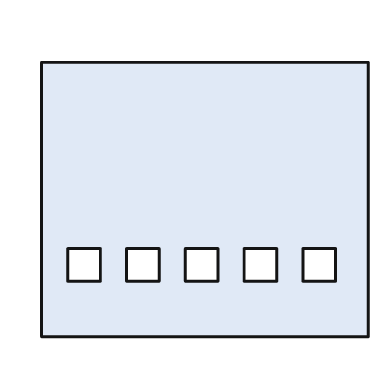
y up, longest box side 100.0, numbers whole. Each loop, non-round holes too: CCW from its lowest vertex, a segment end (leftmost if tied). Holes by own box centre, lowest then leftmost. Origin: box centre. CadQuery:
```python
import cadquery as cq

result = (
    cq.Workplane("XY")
    .moveTo(-50.0, -42.0)
    .lineTo(50.0, -42.0)
    .lineTo(50.0, 42.0)
    .lineTo(-50.0, 42.0)
    .close()
    .moveTo(-42.0, -25.0)
    .lineTo(-32.0, -25.0)
    .lineTo(-32.0, -15.0)
    .lineTo(-42.0, -15.0)
    .close()
    .moveTo(-24.0, -25.0)
    .lineTo(-14.0, -25.0)
    .lineTo(-14.0, -15.0)
    .lineTo(-24.0, -15.0)
    .close()
    .moveTo(-6.0, -25.0)
    .lineTo(4.0, -25.0)
    .lineTo(4.0, -15.0)
    .lineTo(-6.0, -15.0)
    .close()
    .moveTo(12.0, -25.0)
    .lineTo(22.0, -25.0)
    .lineTo(22.0, -15.0)
    .lineTo(12.0, -15.0)
    .close()
    .moveTo(30.0, -25.0)
    .lineTo(40.0, -25.0)
    .lineTo(40.0, -15.0)
    .lineTo(30.0, -15.0)
    .close()
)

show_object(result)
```